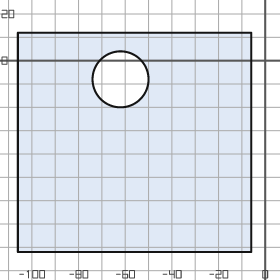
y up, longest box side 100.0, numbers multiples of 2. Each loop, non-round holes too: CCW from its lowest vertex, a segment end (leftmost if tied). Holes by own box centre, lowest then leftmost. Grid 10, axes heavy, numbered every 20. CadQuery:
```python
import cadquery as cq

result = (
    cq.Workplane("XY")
    .moveTo(-106.0, -82.0)
    .lineTo(-6.0, -82.0)
    .lineTo(-6.0, 12.0)
    .lineTo(-106.0, 12.0)
    .close()
    .moveTo(-62.0, -8.0)
    .circle(12.0)
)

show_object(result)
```